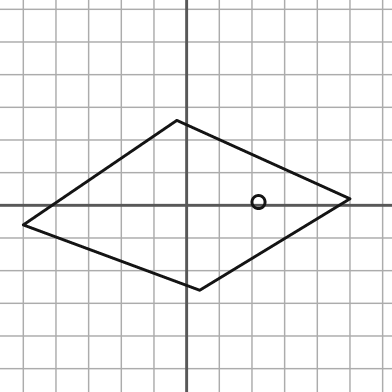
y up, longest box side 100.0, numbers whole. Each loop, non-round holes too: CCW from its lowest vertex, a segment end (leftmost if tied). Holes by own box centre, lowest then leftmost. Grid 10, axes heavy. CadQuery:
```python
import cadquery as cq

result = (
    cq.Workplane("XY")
    .moveTo(4.0, -26.0)
    .lineTo(50.0, 2.0)
    .lineTo(-3.0, 26.0)
    .lineTo(-50.0, -6.0)
    .close()
    .moveTo(22.0, 1.0)
    .circle(2.0)
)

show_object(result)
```